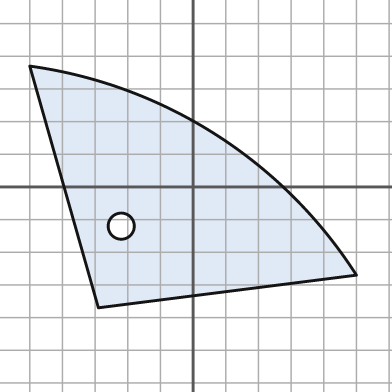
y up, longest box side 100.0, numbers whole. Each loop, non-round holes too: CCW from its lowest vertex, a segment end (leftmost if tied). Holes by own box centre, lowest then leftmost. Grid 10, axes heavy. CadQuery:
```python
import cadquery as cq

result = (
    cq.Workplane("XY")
    .moveTo(-29.0, -37.0)
    .lineTo(50.0, -27.0)
    .threePointArc((7.0, 16.0), (-50.0, 37.0))
    .close()
    .moveTo(-22.0, -12.0)
    .circle(4.0)
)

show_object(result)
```